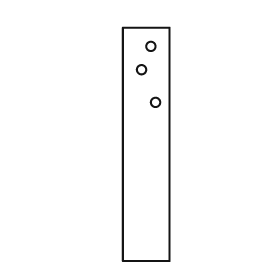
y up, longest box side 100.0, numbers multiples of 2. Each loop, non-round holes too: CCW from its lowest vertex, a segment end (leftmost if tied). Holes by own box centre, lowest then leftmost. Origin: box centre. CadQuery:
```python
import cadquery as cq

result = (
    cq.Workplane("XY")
    .moveTo(-10.0, -50.0)
    .lineTo(10.0, -50.0)
    .lineTo(10.0, 50.0)
    .lineTo(-10.0, 50.0)
    .close()
    .moveTo(4.0, 18.0)
    .circle(2.0)
    .moveTo(-2.0, 32.0)
    .circle(2.0)
    .moveTo(2.0, 42.0)
    .circle(2.0)
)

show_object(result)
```